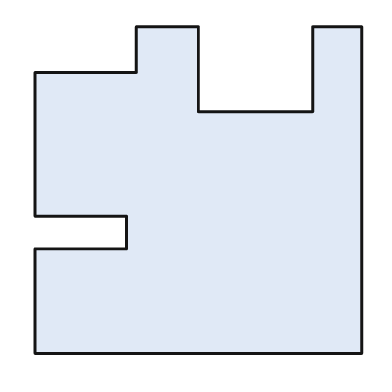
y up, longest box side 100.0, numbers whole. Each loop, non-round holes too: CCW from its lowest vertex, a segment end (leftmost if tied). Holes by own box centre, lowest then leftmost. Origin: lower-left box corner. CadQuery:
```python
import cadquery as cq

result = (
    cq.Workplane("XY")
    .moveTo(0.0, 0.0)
    .lineTo(100.0, 0.0)
    .lineTo(100.0, 100.0)
    .lineTo(85.0, 100.0)
    .lineTo(85.0, 74.0)
    .lineTo(50.0, 74.0)
    .lineTo(50.0, 100.0)
    .lineTo(31.0, 100.0)
    .lineTo(31.0, 86.0)
    .lineTo(0.0, 86.0)
    .lineTo(0.0, 42.0)
    .lineTo(28.0, 42.0)
    .lineTo(28.0, 32.0)
    .lineTo(0.0, 32.0)
    .close()
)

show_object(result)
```